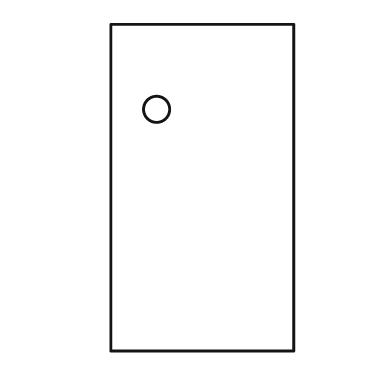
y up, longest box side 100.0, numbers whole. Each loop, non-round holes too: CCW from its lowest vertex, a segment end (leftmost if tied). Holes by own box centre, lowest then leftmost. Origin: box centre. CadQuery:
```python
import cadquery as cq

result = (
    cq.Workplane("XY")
    .moveTo(-28.0, -50.0)
    .lineTo(28.0, -50.0)
    .lineTo(28.0, 50.0)
    .lineTo(-28.0, 50.0)
    .close()
    .moveTo(-14.0, 24.0)
    .circle(4.0)
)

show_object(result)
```